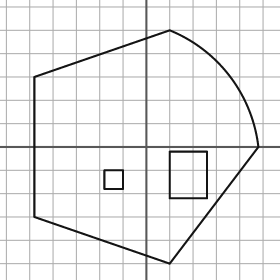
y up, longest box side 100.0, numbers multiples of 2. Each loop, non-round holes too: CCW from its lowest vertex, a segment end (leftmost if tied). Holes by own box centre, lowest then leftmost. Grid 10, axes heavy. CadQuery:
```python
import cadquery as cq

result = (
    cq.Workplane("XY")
    .moveTo(10.0, -50.0)
    .lineTo(48.0, 0.0)
    .threePointArc((36.0, 30.0), (10.0, 50.0))
    .lineTo(-48.0, 30.0)
    .lineTo(-48.0, -30.0)
    .close()
    .moveTo(-18.0, -18.0)
    .lineTo(-10.0, -18.0)
    .lineTo(-10.0, -10.0)
    .lineTo(-18.0, -10.0)
    .close()
    .moveTo(10.0, -22.0)
    .lineTo(26.0, -22.0)
    .lineTo(26.0, -2.0)
    .lineTo(10.0, -2.0)
    .close()
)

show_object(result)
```